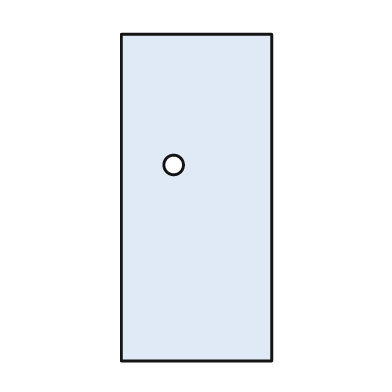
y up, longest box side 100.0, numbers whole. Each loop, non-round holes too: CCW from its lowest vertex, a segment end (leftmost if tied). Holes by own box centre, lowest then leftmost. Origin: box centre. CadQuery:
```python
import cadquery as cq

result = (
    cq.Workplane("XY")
    .moveTo(-23.0, -50.0)
    .lineTo(23.0, -50.0)
    .lineTo(23.0, 50.0)
    .lineTo(-23.0, 50.0)
    .close()
    .moveTo(-7.0, 10.0)
    .circle(3.0)
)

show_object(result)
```